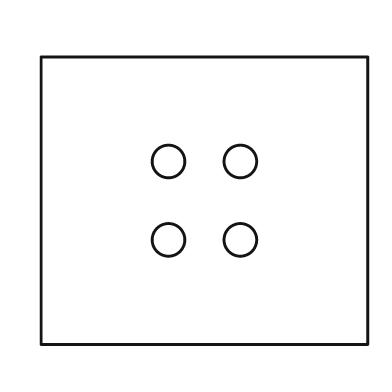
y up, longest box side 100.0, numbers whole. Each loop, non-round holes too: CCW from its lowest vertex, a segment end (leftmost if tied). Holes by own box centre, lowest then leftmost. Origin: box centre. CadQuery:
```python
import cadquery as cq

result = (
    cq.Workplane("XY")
    .moveTo(-50.0, -44.0)
    .lineTo(50.0, -44.0)
    .lineTo(50.0, 44.0)
    .lineTo(-50.0, 44.0)
    .close()
    .moveTo(-11.0, -12.0)
    .circle(5.0)
    .moveTo(11.0, -12.0)
    .circle(5.0)
    .moveTo(-11.0, 12.0)
    .circle(5.0)
    .moveTo(11.0, 12.0)
    .circle(5.0)
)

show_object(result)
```